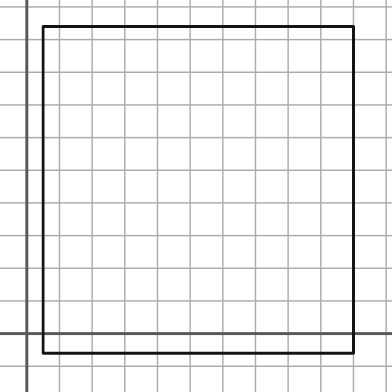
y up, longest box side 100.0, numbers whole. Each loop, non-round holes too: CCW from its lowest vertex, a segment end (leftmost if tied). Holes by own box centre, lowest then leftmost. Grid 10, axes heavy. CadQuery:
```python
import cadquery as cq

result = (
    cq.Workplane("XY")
    .moveTo(5.0, -6.0)
    .lineTo(100.0, -6.0)
    .lineTo(100.0, 94.0)
    .lineTo(5.0, 94.0)
    .close()
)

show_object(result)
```